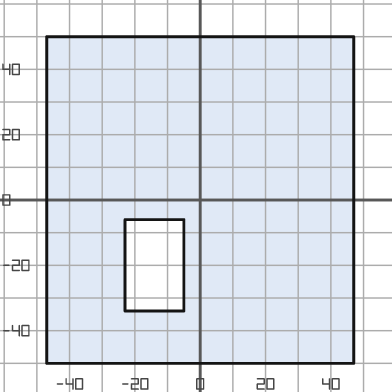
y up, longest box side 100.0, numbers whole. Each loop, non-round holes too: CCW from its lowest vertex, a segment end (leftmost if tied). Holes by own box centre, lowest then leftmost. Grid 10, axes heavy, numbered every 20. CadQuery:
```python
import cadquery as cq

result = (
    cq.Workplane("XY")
    .moveTo(-47.0, -50.0)
    .lineTo(47.0, -50.0)
    .lineTo(47.0, 50.0)
    .lineTo(-47.0, 50.0)
    .close()
    .moveTo(-23.0, -34.0)
    .lineTo(-5.0, -34.0)
    .lineTo(-5.0, -6.0)
    .lineTo(-23.0, -6.0)
    .close()
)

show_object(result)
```